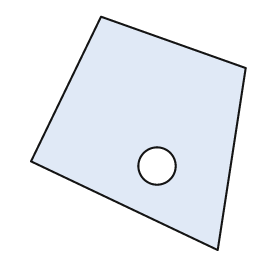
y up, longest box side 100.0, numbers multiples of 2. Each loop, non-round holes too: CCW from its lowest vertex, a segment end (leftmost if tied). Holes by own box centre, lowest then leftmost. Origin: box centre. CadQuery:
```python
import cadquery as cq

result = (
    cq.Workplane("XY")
    .moveTo(34.0, -50.0)
    .lineTo(46.0, 28.0)
    .lineTo(-16.0, 50.0)
    .lineTo(-46.0, -12.0)
    .close()
    .moveTo(8.0, -14.0)
    .circle(8.0)
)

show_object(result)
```